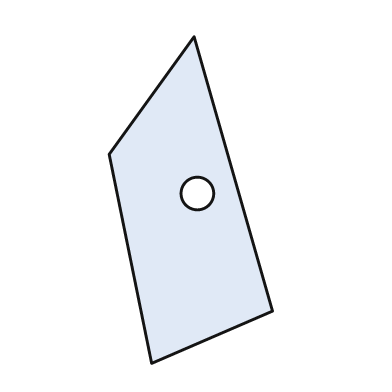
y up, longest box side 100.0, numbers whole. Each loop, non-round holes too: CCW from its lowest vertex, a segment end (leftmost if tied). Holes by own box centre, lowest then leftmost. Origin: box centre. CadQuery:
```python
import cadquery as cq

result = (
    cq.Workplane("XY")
    .moveTo(-12.0, -50.0)
    .lineTo(25.0, -34.0)
    .lineTo(1.0, 50.0)
    .lineTo(-25.0, 14.0)
    .close()
    .moveTo(2.0, 2.0)
    .circle(5.0)
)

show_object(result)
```